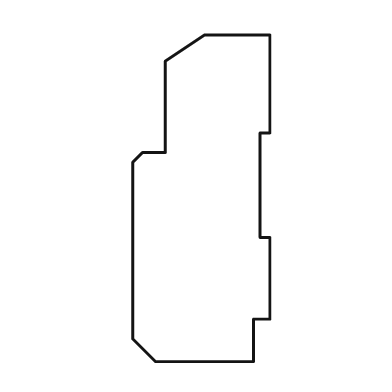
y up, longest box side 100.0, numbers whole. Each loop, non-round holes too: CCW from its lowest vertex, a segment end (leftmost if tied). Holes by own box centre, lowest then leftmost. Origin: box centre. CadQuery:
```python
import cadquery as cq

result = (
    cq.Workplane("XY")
    .moveTo(-14.0, -50.0)
    .lineTo(16.0, -50.0)
    .lineTo(16.0, -37.0)
    .lineTo(21.0, -37.0)
    .lineTo(21.0, -12.0)
    .lineTo(18.0, -12.0)
    .lineTo(18.0, 20.0)
    .lineTo(21.0, 20.0)
    .lineTo(21.0, 50.0)
    .lineTo(1.0, 50.0)
    .lineTo(-11.0, 42.0)
    .lineTo(-11.0, 14.0)
    .lineTo(-18.0, 14.0)
    .lineTo(-21.0, 11.0)
    .lineTo(-21.0, -43.0)
    .close()
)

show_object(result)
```